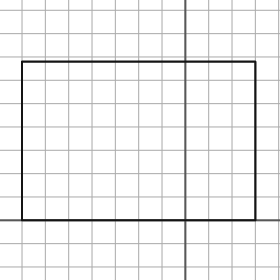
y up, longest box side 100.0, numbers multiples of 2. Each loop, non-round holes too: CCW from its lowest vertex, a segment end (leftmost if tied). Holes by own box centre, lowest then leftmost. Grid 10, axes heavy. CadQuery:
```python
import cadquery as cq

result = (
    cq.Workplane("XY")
    .moveTo(-70.0, 0.0)
    .lineTo(30.0, 0.0)
    .lineTo(30.0, 68.0)
    .lineTo(-70.0, 68.0)
    .close()
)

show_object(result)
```